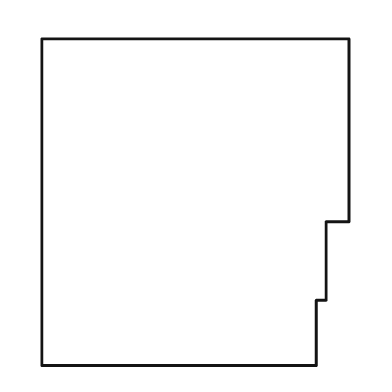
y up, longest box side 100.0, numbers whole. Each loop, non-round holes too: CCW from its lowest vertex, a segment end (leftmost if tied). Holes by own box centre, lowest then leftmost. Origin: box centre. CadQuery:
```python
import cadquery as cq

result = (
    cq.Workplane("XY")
    .moveTo(-47.0, -50.0)
    .lineTo(37.0, -50.0)
    .lineTo(37.0, -30.0)
    .lineTo(40.0, -30.0)
    .lineTo(40.0, -6.0)
    .lineTo(47.0, -6.0)
    .lineTo(47.0, 50.0)
    .lineTo(-47.0, 50.0)
    .close()
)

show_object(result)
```